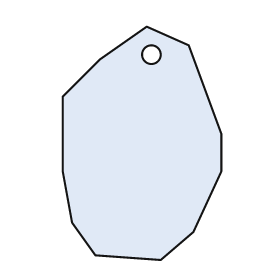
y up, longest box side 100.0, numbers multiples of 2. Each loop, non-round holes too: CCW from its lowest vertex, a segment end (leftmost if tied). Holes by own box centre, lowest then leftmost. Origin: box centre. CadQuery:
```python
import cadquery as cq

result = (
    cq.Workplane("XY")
    .moveTo(8.0, -50.0)
    .lineTo(22.0, -38.0)
    .lineTo(34.0, -12.0)
    .lineTo(34.0, 4.0)
    .lineTo(20.0, 42.0)
    .lineTo(2.0, 50.0)
    .lineTo(-18.0, 36.0)
    .lineTo(-34.0, 20.0)
    .lineTo(-34.0, -12.0)
    .lineTo(-30.0, -34.0)
    .lineTo(-20.0, -48.0)
    .close()
    .moveTo(4.0, 38.0)
    .circle(4.0)
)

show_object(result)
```